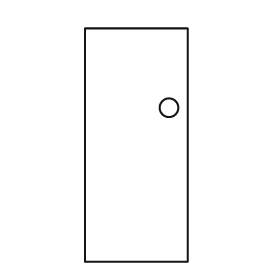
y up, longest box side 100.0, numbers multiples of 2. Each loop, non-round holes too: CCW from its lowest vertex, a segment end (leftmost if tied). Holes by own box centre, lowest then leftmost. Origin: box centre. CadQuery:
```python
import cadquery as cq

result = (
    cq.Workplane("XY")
    .moveTo(-22.0, -50.0)
    .lineTo(22.0, -50.0)
    .lineTo(22.0, 50.0)
    .lineTo(-22.0, 50.0)
    .close()
    .moveTo(14.0, 16.0)
    .circle(4.0)
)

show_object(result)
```